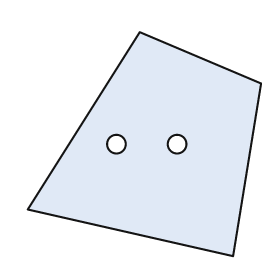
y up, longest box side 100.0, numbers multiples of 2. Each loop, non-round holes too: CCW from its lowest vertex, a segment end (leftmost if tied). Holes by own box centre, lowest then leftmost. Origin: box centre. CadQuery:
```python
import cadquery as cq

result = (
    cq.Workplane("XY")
    .moveTo(38.0, -48.0)
    .lineTo(50.0, 26.0)
    .lineTo(-2.0, 48.0)
    .lineTo(-50.0, -28.0)
    .close()
    .moveTo(-12.0, 0.0)
    .circle(4.0)
    .moveTo(14.0, 0.0)
    .circle(4.0)
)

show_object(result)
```